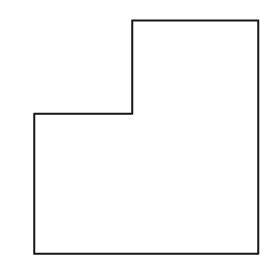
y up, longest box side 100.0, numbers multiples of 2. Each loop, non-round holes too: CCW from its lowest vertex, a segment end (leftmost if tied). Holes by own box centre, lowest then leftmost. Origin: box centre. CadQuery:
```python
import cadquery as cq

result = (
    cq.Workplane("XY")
    .moveTo(-48.0, -50.0)
    .lineTo(48.0, -50.0)
    .lineTo(48.0, 50.0)
    .lineTo(-6.0, 50.0)
    .lineTo(-6.0, 10.0)
    .lineTo(-48.0, 10.0)
    .close()
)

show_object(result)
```